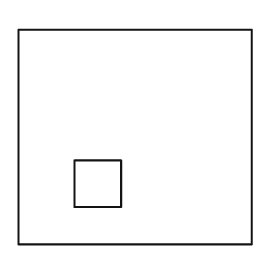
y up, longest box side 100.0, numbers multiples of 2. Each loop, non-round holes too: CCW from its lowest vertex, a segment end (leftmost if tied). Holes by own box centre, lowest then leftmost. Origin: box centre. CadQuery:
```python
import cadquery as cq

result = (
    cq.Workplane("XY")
    .moveTo(-50.0, -46.0)
    .lineTo(50.0, -46.0)
    .lineTo(50.0, 46.0)
    .lineTo(-50.0, 46.0)
    .close()
    .moveTo(-26.0, -30.0)
    .lineTo(-6.0, -30.0)
    .lineTo(-6.0, -10.0)
    .lineTo(-26.0, -10.0)
    .close()
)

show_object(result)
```